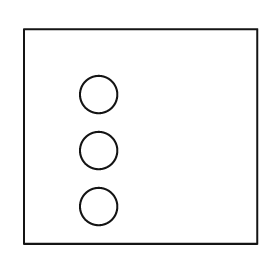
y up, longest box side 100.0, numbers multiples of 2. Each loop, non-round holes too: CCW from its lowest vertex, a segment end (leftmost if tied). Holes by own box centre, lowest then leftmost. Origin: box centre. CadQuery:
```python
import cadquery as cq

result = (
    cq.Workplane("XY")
    .moveTo(-50.0, -46.0)
    .lineTo(50.0, -46.0)
    .lineTo(50.0, 46.0)
    .lineTo(-50.0, 46.0)
    .close()
    .moveTo(-18.0, -30.0)
    .circle(8.0)
    .moveTo(-18.0, -6.0)
    .circle(8.0)
    .moveTo(-18.0, 18.0)
    .circle(8.0)
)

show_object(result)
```